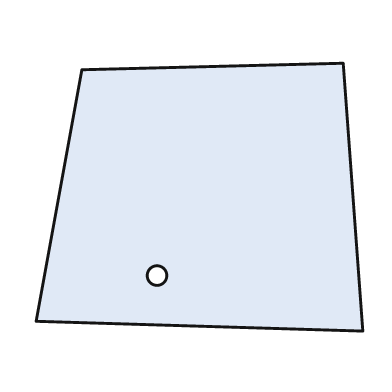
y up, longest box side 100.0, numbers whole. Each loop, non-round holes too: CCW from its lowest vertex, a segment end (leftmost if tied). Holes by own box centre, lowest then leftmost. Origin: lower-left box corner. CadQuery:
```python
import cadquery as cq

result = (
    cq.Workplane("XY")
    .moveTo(100.0, 0.0)
    .lineTo(94.0, 82.0)
    .lineTo(14.0, 80.0)
    .lineTo(0.0, 3.0)
    .close()
    .moveTo(37.0, 17.0)
    .circle(3.0)
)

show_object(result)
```